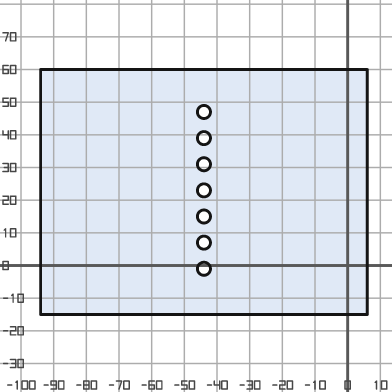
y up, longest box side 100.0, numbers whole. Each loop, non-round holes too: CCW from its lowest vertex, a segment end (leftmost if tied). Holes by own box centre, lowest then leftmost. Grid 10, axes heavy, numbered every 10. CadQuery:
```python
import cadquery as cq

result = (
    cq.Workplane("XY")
    .moveTo(-94.0, -15.0)
    .lineTo(6.0, -15.0)
    .lineTo(6.0, 60.0)
    .lineTo(-94.0, 60.0)
    .close()
    .moveTo(-44.0, -1.0)
    .circle(2.0)
    .moveTo(-44.0, 7.0)
    .circle(2.0)
    .moveTo(-44.0, 15.0)
    .circle(2.0)
    .moveTo(-44.0, 23.0)
    .circle(2.0)
    .moveTo(-44.0, 31.0)
    .circle(2.0)
    .moveTo(-44.0, 39.0)
    .circle(2.0)
    .moveTo(-44.0, 47.0)
    .circle(2.0)
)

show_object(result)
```